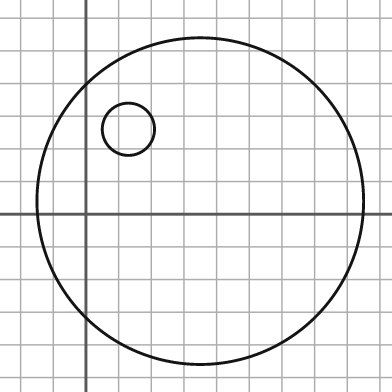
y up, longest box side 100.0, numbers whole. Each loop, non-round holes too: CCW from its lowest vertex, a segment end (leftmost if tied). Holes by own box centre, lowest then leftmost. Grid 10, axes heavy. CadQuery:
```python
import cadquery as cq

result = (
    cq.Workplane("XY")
    .moveTo(35.0, 4.0)
    .circle(50.0)
    .moveTo(13.0, 26.0)
    .circle(8.0)
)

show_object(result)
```